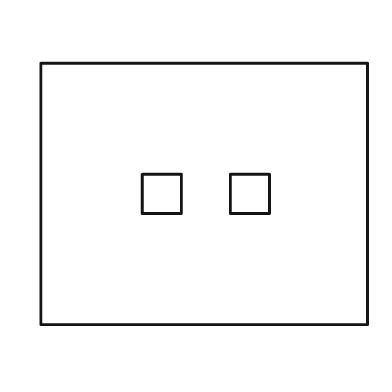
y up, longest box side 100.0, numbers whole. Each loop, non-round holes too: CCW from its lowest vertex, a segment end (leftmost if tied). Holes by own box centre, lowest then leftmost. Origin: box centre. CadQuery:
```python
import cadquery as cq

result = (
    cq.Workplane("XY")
    .moveTo(-50.0, -40.0)
    .lineTo(50.0, -40.0)
    .lineTo(50.0, 40.0)
    .lineTo(-50.0, 40.0)
    .close()
    .moveTo(-19.0, -6.0)
    .lineTo(-7.0, -6.0)
    .lineTo(-7.0, 6.0)
    .lineTo(-19.0, 6.0)
    .close()
    .moveTo(8.0, -6.0)
    .lineTo(20.0, -6.0)
    .lineTo(20.0, 6.0)
    .lineTo(8.0, 6.0)
    .close()
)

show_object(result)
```